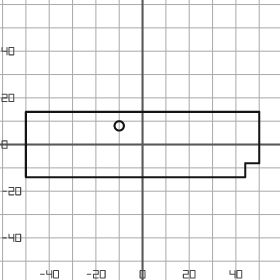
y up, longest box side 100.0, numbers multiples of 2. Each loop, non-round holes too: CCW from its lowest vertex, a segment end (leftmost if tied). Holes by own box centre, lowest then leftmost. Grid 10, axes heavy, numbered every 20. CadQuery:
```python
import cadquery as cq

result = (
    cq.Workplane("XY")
    .moveTo(-50.0, -14.0)
    .lineTo(44.0, -14.0)
    .lineTo(44.0, -8.0)
    .lineTo(50.0, -8.0)
    .lineTo(50.0, 14.0)
    .lineTo(-50.0, 14.0)
    .close()
    .moveTo(-10.0, 8.0)
    .circle(2.0)
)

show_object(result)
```